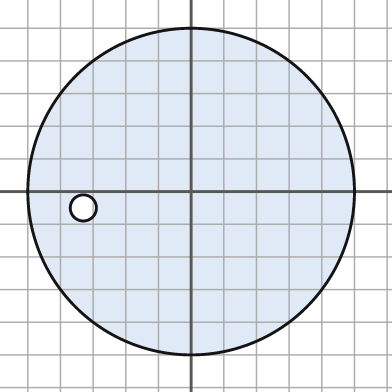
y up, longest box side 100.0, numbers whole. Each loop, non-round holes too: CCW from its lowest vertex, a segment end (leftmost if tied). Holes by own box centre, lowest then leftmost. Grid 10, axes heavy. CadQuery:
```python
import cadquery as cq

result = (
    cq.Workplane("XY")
    .moveTo(0.0, 0.0)
    .circle(50.0)
    .moveTo(-33.0, -5.0)
    .circle(4.0)
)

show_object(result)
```